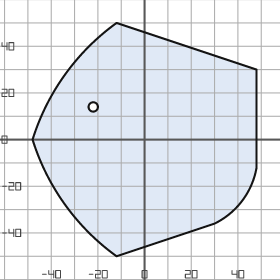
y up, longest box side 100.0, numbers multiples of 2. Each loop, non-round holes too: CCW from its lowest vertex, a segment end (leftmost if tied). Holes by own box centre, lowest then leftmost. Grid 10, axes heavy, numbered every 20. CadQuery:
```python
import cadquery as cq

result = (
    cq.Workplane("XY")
    .moveTo(-12.0, -50.0)
    .lineTo(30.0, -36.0)
    .threePointArc((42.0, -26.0), (48.0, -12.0))
    .lineTo(48.0, 30.0)
    .lineTo(-12.0, 50.0)
    .threePointArc((-34.0, 28.0), (-48.0, 0.0))
    .threePointArc((-34.0, -28.0), (-12.0, -50.0))
    .close()
    .moveTo(-22.0, 14.0)
    .circle(2.0)
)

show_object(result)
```